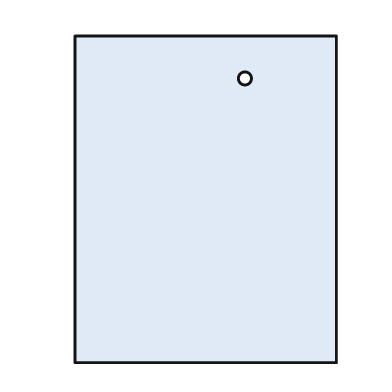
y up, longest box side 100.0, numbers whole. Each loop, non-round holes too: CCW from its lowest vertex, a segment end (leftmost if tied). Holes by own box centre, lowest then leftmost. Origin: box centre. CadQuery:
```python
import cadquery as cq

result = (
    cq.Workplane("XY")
    .moveTo(-40.0, -50.0)
    .lineTo(40.0, -50.0)
    .lineTo(40.0, 50.0)
    .lineTo(-40.0, 50.0)
    .close()
    .moveTo(12.0, 37.0)
    .circle(2.0)
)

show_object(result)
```